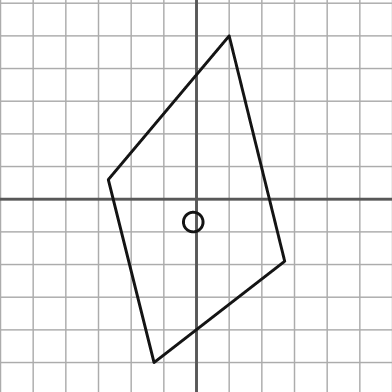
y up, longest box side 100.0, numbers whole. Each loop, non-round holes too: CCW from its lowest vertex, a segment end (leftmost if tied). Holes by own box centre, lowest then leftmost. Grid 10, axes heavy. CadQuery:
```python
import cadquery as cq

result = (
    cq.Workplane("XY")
    .moveTo(-13.0, -50.0)
    .lineTo(27.0, -19.0)
    .lineTo(10.0, 50.0)
    .lineTo(-27.0, 6.0)
    .close()
    .moveTo(-1.0, -7.0)
    .circle(3.0)
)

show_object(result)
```